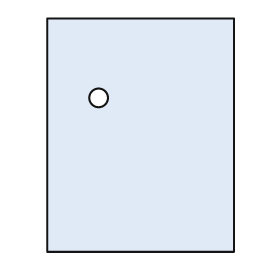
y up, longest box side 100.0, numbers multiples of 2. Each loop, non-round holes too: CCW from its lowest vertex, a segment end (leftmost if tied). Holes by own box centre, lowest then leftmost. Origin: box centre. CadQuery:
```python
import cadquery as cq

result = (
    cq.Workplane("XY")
    .moveTo(-40.0, -50.0)
    .lineTo(40.0, -50.0)
    .lineTo(40.0, 50.0)
    .lineTo(-40.0, 50.0)
    .close()
    .moveTo(-18.0, 16.0)
    .circle(4.0)
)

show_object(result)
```